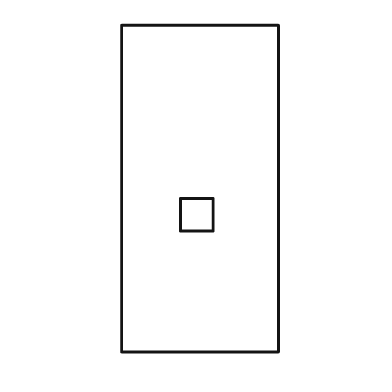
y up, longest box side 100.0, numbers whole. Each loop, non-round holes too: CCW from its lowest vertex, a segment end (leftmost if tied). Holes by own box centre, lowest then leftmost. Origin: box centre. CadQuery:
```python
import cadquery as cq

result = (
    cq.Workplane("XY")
    .moveTo(-24.0, -50.0)
    .lineTo(24.0, -50.0)
    .lineTo(24.0, 50.0)
    .lineTo(-24.0, 50.0)
    .close()
    .moveTo(-6.0, -13.0)
    .lineTo(4.0, -13.0)
    .lineTo(4.0, -3.0)
    .lineTo(-6.0, -3.0)
    .close()
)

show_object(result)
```